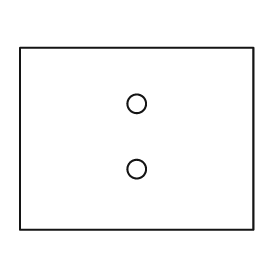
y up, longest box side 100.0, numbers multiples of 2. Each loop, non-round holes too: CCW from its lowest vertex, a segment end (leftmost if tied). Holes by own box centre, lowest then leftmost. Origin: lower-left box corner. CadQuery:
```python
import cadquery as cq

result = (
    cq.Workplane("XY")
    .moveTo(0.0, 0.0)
    .lineTo(100.0, 0.0)
    .lineTo(100.0, 78.0)
    .lineTo(0.0, 78.0)
    .close()
    .moveTo(50.0, 26.0)
    .circle(4.0)
    .moveTo(50.0, 54.0)
    .circle(4.0)
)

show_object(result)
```